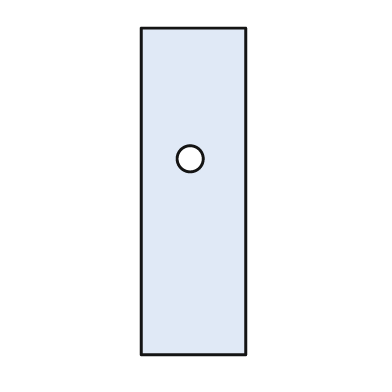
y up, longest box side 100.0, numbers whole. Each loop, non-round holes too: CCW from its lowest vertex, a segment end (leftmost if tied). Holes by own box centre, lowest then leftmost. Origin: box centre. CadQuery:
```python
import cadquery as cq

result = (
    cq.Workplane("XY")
    .moveTo(-16.0, -50.0)
    .lineTo(16.0, -50.0)
    .lineTo(16.0, 50.0)
    .lineTo(-16.0, 50.0)
    .close()
    .moveTo(-1.0, 10.0)
    .circle(4.0)
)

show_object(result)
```